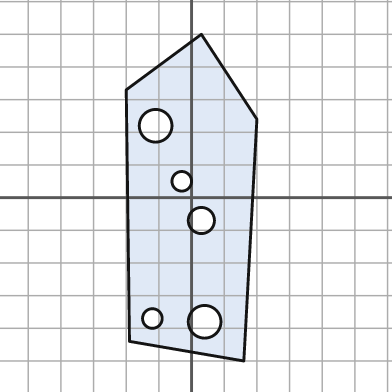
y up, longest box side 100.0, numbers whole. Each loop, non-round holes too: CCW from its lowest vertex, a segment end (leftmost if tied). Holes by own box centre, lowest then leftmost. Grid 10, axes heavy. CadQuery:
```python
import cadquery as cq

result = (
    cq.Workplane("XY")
    .moveTo(16.0, -50.0)
    .lineTo(20.0, 24.0)
    .lineTo(3.0, 50.0)
    .lineTo(-20.0, 33.0)
    .lineTo(-19.0, -44.0)
    .close()
    .moveTo(4.0, -38.0)
    .circle(5.0)
    .moveTo(-12.0, -37.0)
    .circle(3.0)
    .moveTo(3.0, -7.0)
    .circle(4.0)
    .moveTo(-3.0, 5.0)
    .circle(3.0)
    .moveTo(-11.0, 22.0)
    .circle(5.0)
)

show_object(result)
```